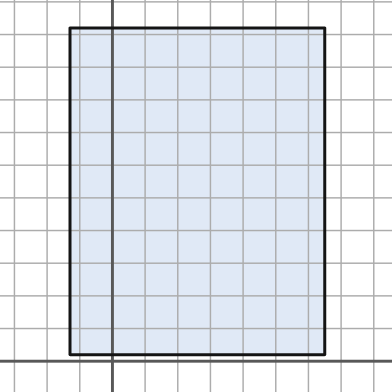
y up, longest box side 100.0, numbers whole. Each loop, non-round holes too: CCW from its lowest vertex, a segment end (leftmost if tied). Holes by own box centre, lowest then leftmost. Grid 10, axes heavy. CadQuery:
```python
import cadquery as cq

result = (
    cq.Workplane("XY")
    .moveTo(-13.0, 2.0)
    .lineTo(65.0, 2.0)
    .lineTo(65.0, 102.0)
    .lineTo(-13.0, 102.0)
    .close()
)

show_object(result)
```